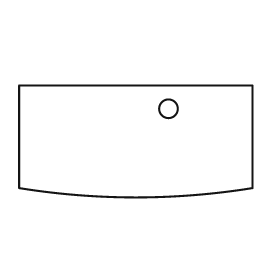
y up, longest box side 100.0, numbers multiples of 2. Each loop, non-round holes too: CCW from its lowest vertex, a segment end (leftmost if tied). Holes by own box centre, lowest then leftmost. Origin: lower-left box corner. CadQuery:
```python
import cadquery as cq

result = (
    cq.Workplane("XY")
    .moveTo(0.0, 4.0)
    .threePointArc((50.0, 0.0), (100.0, 4.0))
    .lineTo(100.0, 48.0)
    .lineTo(0.0, 48.0)
    .close()
    .moveTo(64.0, 38.0)
    .circle(4.0)
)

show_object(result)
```